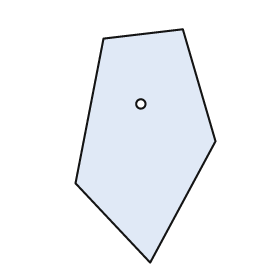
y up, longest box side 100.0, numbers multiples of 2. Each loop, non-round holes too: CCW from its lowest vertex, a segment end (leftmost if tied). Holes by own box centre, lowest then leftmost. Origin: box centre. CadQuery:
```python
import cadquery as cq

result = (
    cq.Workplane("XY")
    .moveTo(2.0, -50.0)
    .lineTo(30.0, 2.0)
    .lineTo(16.0, 50.0)
    .lineTo(-18.0, 46.0)
    .lineTo(-30.0, -16.0)
    .close()
    .moveTo(-2.0, 18.0)
    .circle(2.0)
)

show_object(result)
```